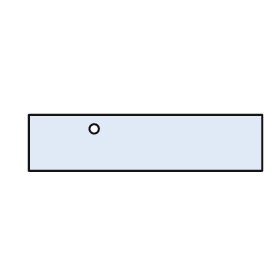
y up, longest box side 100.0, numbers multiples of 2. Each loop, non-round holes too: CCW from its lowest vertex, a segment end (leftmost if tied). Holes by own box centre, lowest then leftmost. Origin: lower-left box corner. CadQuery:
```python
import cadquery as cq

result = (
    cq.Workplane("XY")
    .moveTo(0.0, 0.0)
    .lineTo(100.0, 0.0)
    .lineTo(100.0, 24.0)
    .lineTo(0.0, 24.0)
    .close()
    .moveTo(28.0, 18.0)
    .circle(2.0)
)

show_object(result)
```